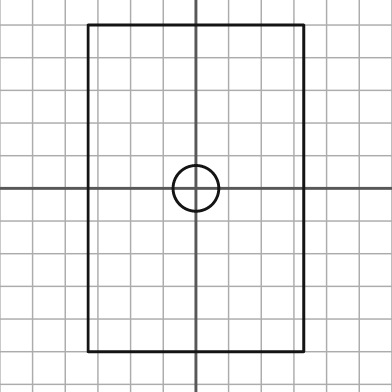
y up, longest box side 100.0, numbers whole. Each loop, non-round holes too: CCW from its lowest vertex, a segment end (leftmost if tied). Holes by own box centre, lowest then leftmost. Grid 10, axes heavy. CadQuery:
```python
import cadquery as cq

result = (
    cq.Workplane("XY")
    .moveTo(-33.0, -50.0)
    .lineTo(33.0, -50.0)
    .lineTo(33.0, 50.0)
    .lineTo(-33.0, 50.0)
    .close()
    .moveTo(0.0, 0.0)
    .circle(7.0)
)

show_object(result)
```